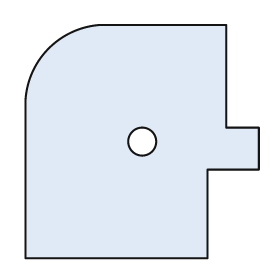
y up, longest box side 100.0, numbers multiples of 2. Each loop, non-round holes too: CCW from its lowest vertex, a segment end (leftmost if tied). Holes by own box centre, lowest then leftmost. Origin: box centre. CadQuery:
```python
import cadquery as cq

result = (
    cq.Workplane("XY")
    .moveTo(-50.0, -50.0)
    .lineTo(28.0, -50.0)
    .lineTo(28.0, -12.0)
    .lineTo(50.0, -12.0)
    .lineTo(50.0, 6.0)
    .lineTo(36.0, 6.0)
    .lineTo(36.0, 50.0)
    .lineTo(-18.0, 50.0)
    .threePointArc((-40.0, 40.0), (-50.0, 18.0))
    .close()
    .moveTo(0.0, 0.0)
    .circle(6.0)
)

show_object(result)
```